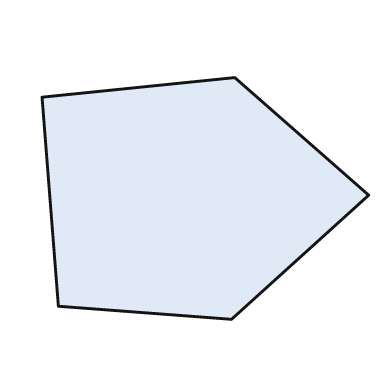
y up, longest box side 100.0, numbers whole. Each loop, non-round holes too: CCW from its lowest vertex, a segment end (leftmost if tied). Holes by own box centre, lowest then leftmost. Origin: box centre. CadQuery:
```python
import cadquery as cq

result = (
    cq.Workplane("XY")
    .moveTo(8.0, -37.0)
    .lineTo(50.0, 1.0)
    .lineTo(9.0, 37.0)
    .lineTo(-50.0, 31.0)
    .lineTo(-45.0, -33.0)
    .close()
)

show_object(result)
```